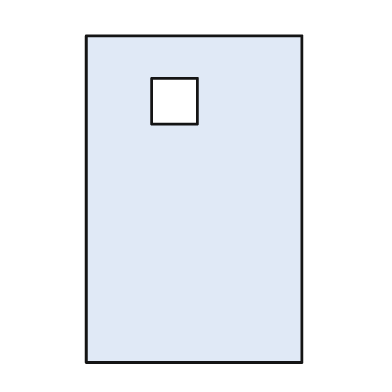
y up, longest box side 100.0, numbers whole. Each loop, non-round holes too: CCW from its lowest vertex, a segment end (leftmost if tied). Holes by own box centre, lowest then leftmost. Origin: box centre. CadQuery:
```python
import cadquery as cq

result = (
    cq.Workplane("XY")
    .moveTo(-33.0, -50.0)
    .lineTo(33.0, -50.0)
    .lineTo(33.0, 50.0)
    .lineTo(-33.0, 50.0)
    .close()
    .moveTo(-13.0, 23.0)
    .lineTo(1.0, 23.0)
    .lineTo(1.0, 37.0)
    .lineTo(-13.0, 37.0)
    .close()
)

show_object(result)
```